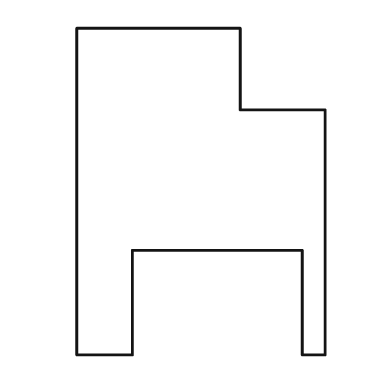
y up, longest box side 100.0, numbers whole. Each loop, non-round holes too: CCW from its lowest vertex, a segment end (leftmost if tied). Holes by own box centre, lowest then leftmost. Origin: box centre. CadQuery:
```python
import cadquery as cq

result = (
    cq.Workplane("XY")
    .moveTo(-38.0, -50.0)
    .lineTo(-21.0, -50.0)
    .lineTo(-21.0, -18.0)
    .lineTo(31.0, -18.0)
    .lineTo(31.0, -50.0)
    .lineTo(38.0, -50.0)
    .lineTo(38.0, 25.0)
    .lineTo(12.0, 25.0)
    .lineTo(12.0, 50.0)
    .lineTo(-38.0, 50.0)
    .close()
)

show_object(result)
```